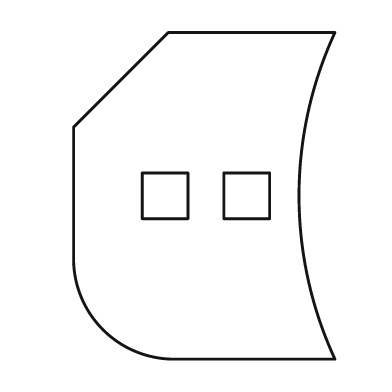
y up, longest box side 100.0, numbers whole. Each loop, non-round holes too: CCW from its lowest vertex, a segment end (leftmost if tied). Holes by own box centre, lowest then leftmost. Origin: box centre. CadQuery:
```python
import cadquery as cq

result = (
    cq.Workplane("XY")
    .moveTo(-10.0, -50.0)
    .lineTo(40.0, -50.0)
    .threePointArc((29.0, 0.0), (40.0, 50.0))
    .lineTo(-11.0, 50.0)
    .lineTo(-40.0, 21.0)
    .lineTo(-40.0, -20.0)
    .threePointArc((-31.0, -41.0), (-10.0, -50.0))
    .close()
    .moveTo(-19.0, -7.0)
    .lineTo(-5.0, -7.0)
    .lineTo(-5.0, 7.0)
    .lineTo(-19.0, 7.0)
    .close()
    .moveTo(6.0, -7.0)
    .lineTo(20.0, -7.0)
    .lineTo(20.0, 7.0)
    .lineTo(6.0, 7.0)
    .close()
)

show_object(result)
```